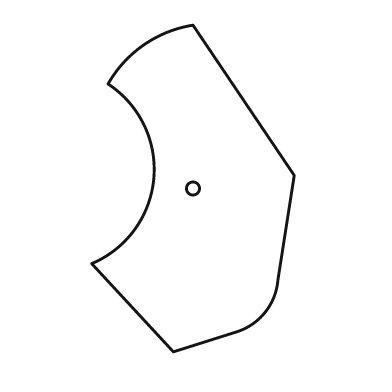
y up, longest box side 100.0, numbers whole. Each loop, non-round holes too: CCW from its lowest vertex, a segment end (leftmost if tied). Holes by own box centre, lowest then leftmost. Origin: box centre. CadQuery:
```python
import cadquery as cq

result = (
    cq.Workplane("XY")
    .moveTo(-6.0, -50.0)
    .lineTo(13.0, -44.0)
    .threePointArc((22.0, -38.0), (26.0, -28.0))
    .lineTo(31.0, 4.0)
    .lineTo(0.0, 50.0)
    .threePointArc((-15.0, 44.0), (-26.0, 32.0))
    .threePointArc((-12.0, 3.0), (-31.0, -23.0))
    .close()
    .moveTo(0.0, 0.0)
    .circle(2.0)
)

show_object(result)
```